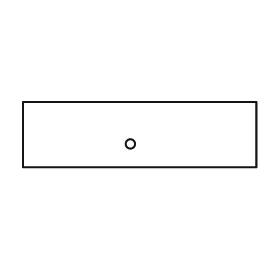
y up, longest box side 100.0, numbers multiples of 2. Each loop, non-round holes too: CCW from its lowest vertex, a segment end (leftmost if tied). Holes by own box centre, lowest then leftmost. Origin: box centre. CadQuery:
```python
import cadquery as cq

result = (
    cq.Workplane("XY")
    .moveTo(-50.0, -14.0)
    .lineTo(50.0, -14.0)
    .lineTo(50.0, 14.0)
    .lineTo(-50.0, 14.0)
    .close()
    .moveTo(-4.0, -4.0)
    .circle(2.0)
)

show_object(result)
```